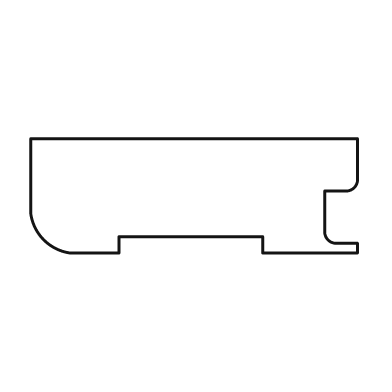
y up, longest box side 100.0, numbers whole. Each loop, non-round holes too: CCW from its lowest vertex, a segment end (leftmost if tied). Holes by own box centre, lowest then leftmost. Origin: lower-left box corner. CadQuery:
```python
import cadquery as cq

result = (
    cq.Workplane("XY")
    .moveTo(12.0, 0.0)
    .lineTo(27.0, 0.0)
    .lineTo(27.0, 5.0)
    .lineTo(71.0, 5.0)
    .lineTo(71.0, 0.0)
    .lineTo(100.0, 0.0)
    .lineTo(100.0, 3.0)
    .lineTo(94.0, 3.0)
    .threePointArc((91.0, 4.0), (90.0, 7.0))
    .lineTo(90.0, 19.0)
    .lineTo(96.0, 19.0)
    .threePointArc((99.0, 20.0), (100.0, 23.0))
    .lineTo(100.0, 35.0)
    .lineTo(0.0, 35.0)
    .lineTo(0.0, 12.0)
    .threePointArc((4.0, 4.0), (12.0, 0.0))
    .close()
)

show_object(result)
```